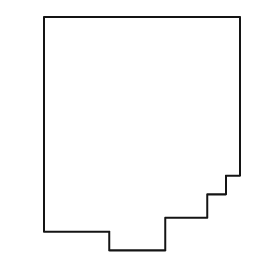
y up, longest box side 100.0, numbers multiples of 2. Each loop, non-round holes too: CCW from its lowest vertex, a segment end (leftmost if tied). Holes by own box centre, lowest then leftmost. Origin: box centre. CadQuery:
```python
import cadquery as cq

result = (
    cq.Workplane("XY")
    .moveTo(-14.0, -50.0)
    .lineTo(10.0, -50.0)
    .lineTo(10.0, -36.0)
    .lineTo(28.0, -36.0)
    .lineTo(28.0, -26.0)
    .lineTo(36.0, -26.0)
    .lineTo(36.0, -18.0)
    .lineTo(42.0, -18.0)
    .lineTo(42.0, 50.0)
    .lineTo(-42.0, 50.0)
    .lineTo(-42.0, -42.0)
    .lineTo(-14.0, -42.0)
    .close()
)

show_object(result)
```